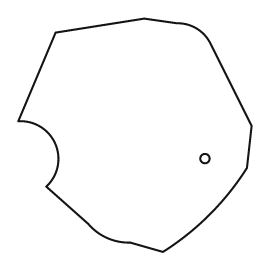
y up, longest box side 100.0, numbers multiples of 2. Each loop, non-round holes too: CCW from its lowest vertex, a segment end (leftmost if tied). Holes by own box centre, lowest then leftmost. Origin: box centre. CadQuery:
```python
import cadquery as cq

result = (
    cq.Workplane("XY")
    .moveTo(12.0, -50.0)
    .threePointArc((32.0, -34.0), (48.0, -14.0))
    .lineTo(50.0, 4.0)
    .lineTo(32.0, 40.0)
    .threePointArc((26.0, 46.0), (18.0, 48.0))
    .lineTo(4.0, 50.0)
    .lineTo(-34.0, 44.0)
    .lineTo(-50.0, 6.0)
    .threePointArc((-34.0, -4.0), (-38.0, -22.0))
    .lineTo(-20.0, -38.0)
    .threePointArc((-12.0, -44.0), (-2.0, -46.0))
    .close()
    .moveTo(30.0, -10.0)
    .circle(2.0)
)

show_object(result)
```